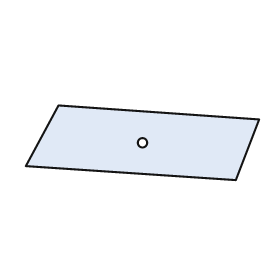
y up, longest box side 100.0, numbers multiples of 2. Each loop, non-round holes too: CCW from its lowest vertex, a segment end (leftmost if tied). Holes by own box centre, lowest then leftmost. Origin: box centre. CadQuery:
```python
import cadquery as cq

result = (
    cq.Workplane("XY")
    .moveTo(40.0, -16.0)
    .lineTo(50.0, 10.0)
    .lineTo(-36.0, 16.0)
    .lineTo(-50.0, -10.0)
    .close()
    .moveTo(0.0, 0.0)
    .circle(2.0)
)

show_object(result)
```